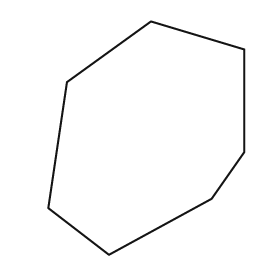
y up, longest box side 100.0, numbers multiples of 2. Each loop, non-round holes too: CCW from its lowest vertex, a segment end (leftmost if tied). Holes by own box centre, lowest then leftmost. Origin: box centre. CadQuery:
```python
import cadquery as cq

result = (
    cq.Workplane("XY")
    .moveTo(-16.0, -50.0)
    .lineTo(28.0, -26.0)
    .lineTo(42.0, -6.0)
    .lineTo(42.0, 38.0)
    .lineTo(2.0, 50.0)
    .lineTo(-34.0, 24.0)
    .lineTo(-42.0, -30.0)
    .close()
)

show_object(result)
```